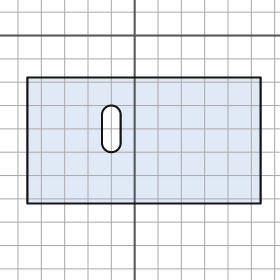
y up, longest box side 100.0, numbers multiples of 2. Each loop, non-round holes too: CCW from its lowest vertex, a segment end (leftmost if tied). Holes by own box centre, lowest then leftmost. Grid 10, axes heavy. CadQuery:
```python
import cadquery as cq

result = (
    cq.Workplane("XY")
    .moveTo(-46.0, -72.0)
    .lineTo(54.0, -72.0)
    .lineTo(54.0, -18.0)
    .lineTo(-46.0, -18.0)
    .close()
    .moveTo(-14.0, -46.0)
    .threePointArc((-10.0, -50.0), (-6.0, -46.0))
    .lineTo(-6.0, -34.0)
    .threePointArc((-10.0, -30.0), (-14.0, -34.0))
    .close()
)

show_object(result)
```